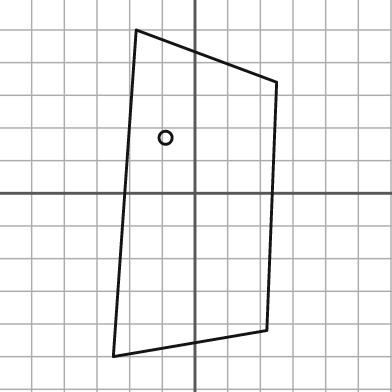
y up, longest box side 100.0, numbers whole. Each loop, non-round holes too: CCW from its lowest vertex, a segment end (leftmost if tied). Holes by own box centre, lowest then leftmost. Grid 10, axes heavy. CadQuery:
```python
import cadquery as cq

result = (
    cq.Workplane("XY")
    .moveTo(-25.0, -50.0)
    .lineTo(22.0, -42.0)
    .lineTo(25.0, 34.0)
    .lineTo(-18.0, 50.0)
    .close()
    .moveTo(-9.0, 17.0)
    .circle(2.0)
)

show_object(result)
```